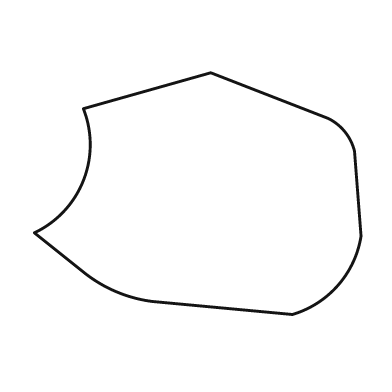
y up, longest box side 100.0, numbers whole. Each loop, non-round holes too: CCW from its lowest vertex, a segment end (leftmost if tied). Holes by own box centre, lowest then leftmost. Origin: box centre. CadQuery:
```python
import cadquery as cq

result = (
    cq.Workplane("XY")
    .moveTo(29.0, -37.0)
    .threePointArc((43.0, -28.0), (50.0, -13.0))
    .lineTo(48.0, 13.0)
    .threePointArc((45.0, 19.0), (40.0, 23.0))
    .lineTo(4.0, 37.0)
    .lineTo(-35.0, 26.0)
    .threePointArc((-35.0, 4.0), (-50.0, -12.0))
    .lineTo(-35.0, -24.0)
    .threePointArc((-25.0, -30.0), (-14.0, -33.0))
    .close()
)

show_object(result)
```